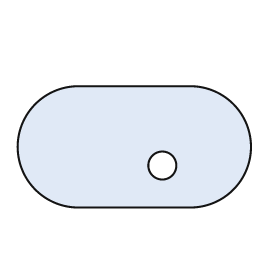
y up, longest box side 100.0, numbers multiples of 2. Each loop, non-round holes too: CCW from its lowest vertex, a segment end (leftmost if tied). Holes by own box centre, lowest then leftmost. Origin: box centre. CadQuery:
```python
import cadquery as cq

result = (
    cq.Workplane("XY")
    .moveTo(-24.0, -26.0)
    .lineTo(24.0, -26.0)
    .threePointArc((50.0, 0.0), (24.0, 26.0))
    .lineTo(-24.0, 26.0)
    .threePointArc((-50.0, 0.0), (-24.0, -26.0))
    .close()
    .moveTo(12.0, -8.0)
    .circle(6.0)
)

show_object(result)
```